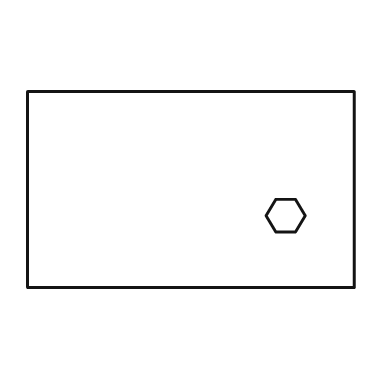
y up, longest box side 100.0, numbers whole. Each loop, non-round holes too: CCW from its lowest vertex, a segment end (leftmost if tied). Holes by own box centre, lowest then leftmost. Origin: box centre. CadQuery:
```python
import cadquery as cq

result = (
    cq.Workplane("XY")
    .moveTo(-50.0, -30.0)
    .lineTo(50.0, -30.0)
    .lineTo(50.0, 30.0)
    .lineTo(-50.0, 30.0)
    .close()
    .moveTo(26.0, -13.0)
    .lineTo(32.0, -13.0)
    .lineTo(35.0, -8.0)
    .lineTo(32.0, -3.0)
    .lineTo(26.0, -3.0)
    .lineTo(23.0, -8.0)
    .close()
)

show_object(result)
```